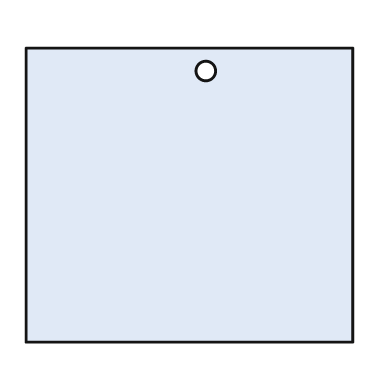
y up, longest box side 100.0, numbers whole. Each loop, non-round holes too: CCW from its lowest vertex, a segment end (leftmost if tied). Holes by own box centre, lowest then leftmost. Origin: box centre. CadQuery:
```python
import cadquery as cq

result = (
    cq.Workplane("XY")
    .moveTo(-50.0, -45.0)
    .lineTo(50.0, -45.0)
    .lineTo(50.0, 45.0)
    .lineTo(-50.0, 45.0)
    .close()
    .moveTo(5.0, 38.0)
    .circle(3.0)
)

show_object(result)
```